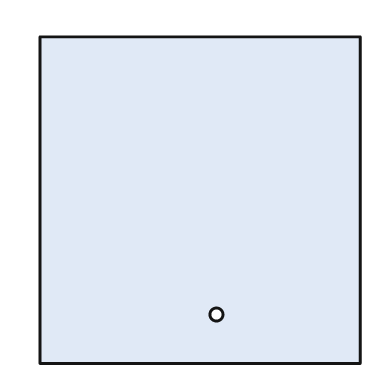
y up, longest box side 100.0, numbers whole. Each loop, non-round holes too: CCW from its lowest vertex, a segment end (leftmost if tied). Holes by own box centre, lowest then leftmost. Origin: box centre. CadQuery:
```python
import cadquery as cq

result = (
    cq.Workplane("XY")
    .moveTo(-49.0, -50.0)
    .lineTo(49.0, -50.0)
    .lineTo(49.0, 50.0)
    .lineTo(-49.0, 50.0)
    .close()
    .moveTo(5.0, -35.0)
    .circle(2.0)
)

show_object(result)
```